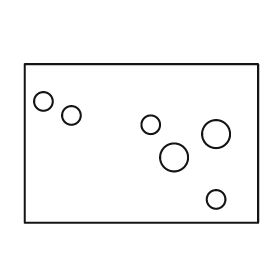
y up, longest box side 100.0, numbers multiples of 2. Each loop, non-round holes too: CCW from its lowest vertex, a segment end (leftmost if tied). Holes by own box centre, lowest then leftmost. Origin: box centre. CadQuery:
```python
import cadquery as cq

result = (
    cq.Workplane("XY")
    .moveTo(-50.0, -34.0)
    .lineTo(50.0, -34.0)
    .lineTo(50.0, 34.0)
    .lineTo(-50.0, 34.0)
    .close()
    .moveTo(32.0, -24.0)
    .circle(4.0)
    .moveTo(14.0, -6.0)
    .circle(6.0)
    .moveTo(32.0, 4.0)
    .circle(6.0)
    .moveTo(4.0, 8.0)
    .circle(4.0)
    .moveTo(-30.0, 12.0)
    .circle(4.0)
    .moveTo(-42.0, 18.0)
    .circle(4.0)
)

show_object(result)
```